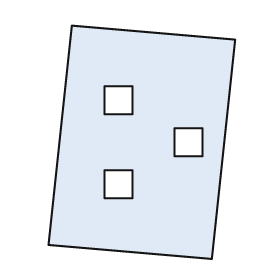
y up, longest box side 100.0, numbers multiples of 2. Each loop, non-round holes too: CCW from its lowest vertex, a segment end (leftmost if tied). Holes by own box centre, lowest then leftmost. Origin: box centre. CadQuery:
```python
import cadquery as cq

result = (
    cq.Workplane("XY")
    .moveTo(30.0, -50.0)
    .lineTo(40.0, 44.0)
    .lineTo(-30.0, 50.0)
    .lineTo(-40.0, -44.0)
    .close()
    .moveTo(-16.0, -24.0)
    .lineTo(-4.0, -24.0)
    .lineTo(-4.0, -12.0)
    .lineTo(-16.0, -12.0)
    .close()
    .moveTo(14.0, -6.0)
    .lineTo(26.0, -6.0)
    .lineTo(26.0, 6.0)
    .lineTo(14.0, 6.0)
    .close()
    .moveTo(-16.0, 12.0)
    .lineTo(-4.0, 12.0)
    .lineTo(-4.0, 24.0)
    .lineTo(-16.0, 24.0)
    .close()
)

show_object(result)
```